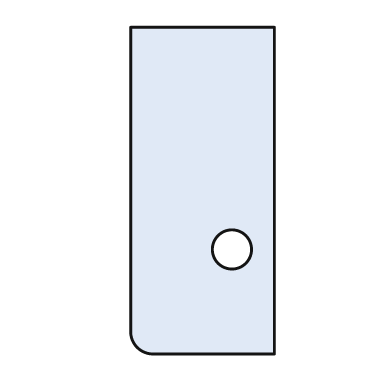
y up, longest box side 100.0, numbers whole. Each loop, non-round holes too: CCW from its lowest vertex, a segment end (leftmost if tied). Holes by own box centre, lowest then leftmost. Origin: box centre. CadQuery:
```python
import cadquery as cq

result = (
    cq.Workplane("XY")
    .moveTo(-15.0, -50.0)
    .lineTo(22.0, -50.0)
    .lineTo(22.0, 50.0)
    .lineTo(-22.0, 50.0)
    .lineTo(-22.0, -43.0)
    .threePointArc((-20.0, -48.0), (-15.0, -50.0))
    .close()
    .moveTo(9.0, -18.0)
    .circle(6.0)
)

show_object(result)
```